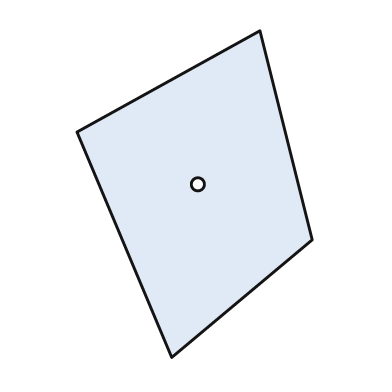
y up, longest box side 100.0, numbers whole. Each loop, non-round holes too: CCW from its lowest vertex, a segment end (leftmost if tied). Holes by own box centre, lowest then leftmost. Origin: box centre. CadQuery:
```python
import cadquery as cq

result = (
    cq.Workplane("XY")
    .moveTo(-7.0, -50.0)
    .lineTo(36.0, -14.0)
    .lineTo(20.0, 50.0)
    .lineTo(-36.0, 19.0)
    .close()
    .moveTo(1.0, 3.0)
    .circle(2.0)
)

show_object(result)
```